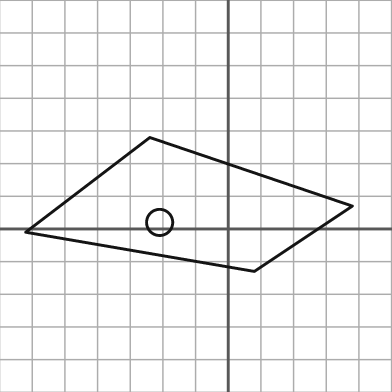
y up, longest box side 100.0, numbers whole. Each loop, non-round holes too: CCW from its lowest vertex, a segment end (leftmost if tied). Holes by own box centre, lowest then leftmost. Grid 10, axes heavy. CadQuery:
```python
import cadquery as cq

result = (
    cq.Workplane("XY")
    .moveTo(8.0, -13.0)
    .lineTo(38.0, 7.0)
    .lineTo(-24.0, 28.0)
    .lineTo(-62.0, -1.0)
    .close()
    .moveTo(-21.0, 2.0)
    .circle(4.0)
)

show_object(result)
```